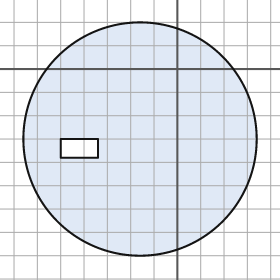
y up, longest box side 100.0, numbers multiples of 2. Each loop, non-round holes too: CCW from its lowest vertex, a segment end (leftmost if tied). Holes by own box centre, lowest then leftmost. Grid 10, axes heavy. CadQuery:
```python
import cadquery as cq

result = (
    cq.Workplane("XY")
    .moveTo(-16.0, -30.0)
    .circle(50.0)
    .moveTo(-50.0, -38.0)
    .lineTo(-34.0, -38.0)
    .lineTo(-34.0, -30.0)
    .lineTo(-50.0, -30.0)
    .close()
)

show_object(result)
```